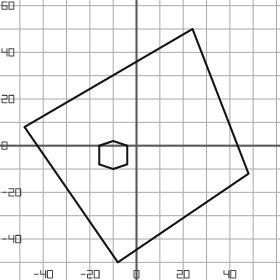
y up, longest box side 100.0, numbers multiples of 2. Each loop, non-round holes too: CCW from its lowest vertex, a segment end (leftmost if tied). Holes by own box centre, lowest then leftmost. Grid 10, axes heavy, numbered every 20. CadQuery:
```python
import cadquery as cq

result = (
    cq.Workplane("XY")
    .moveTo(-8.0, -50.0)
    .lineTo(48.0, -12.0)
    .lineTo(24.0, 50.0)
    .lineTo(-48.0, 8.0)
    .close()
    .moveTo(-10.0, -10.0)
    .lineTo(-4.0, -8.0)
    .lineTo(-4.0, 0.0)
    .lineTo(-10.0, 2.0)
    .lineTo(-16.0, 0.0)
    .lineTo(-16.0, -8.0)
    .close()
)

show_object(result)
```